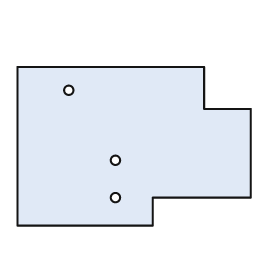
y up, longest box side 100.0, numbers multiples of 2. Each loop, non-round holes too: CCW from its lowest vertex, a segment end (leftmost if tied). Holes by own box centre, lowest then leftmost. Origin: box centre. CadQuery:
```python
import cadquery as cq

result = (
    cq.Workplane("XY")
    .moveTo(-50.0, -34.0)
    .lineTo(8.0, -34.0)
    .lineTo(8.0, -22.0)
    .lineTo(50.0, -22.0)
    .lineTo(50.0, 16.0)
    .lineTo(30.0, 16.0)
    .lineTo(30.0, 34.0)
    .lineTo(-50.0, 34.0)
    .close()
    .moveTo(-8.0, -22.0)
    .circle(2.0)
    .moveTo(-8.0, -6.0)
    .circle(2.0)
    .moveTo(-28.0, 24.0)
    .circle(2.0)
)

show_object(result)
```